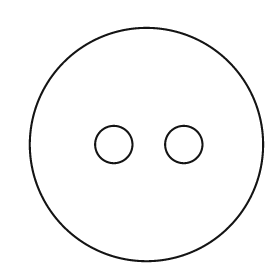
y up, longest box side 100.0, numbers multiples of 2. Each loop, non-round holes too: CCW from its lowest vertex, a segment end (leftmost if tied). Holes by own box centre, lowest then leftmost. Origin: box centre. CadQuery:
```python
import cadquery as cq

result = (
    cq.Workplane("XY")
    .moveTo(0.0, 0.0)
    .circle(50.0)
    .moveTo(-14.0, 0.0)
    .circle(8.0)
    .moveTo(16.0, 0.0)
    .circle(8.0)
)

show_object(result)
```